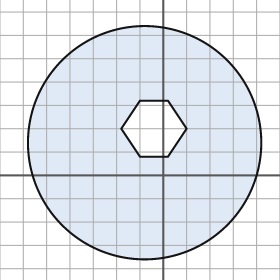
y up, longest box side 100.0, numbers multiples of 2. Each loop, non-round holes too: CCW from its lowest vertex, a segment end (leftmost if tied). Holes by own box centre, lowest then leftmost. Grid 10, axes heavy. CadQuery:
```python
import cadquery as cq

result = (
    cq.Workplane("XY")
    .moveTo(-8.0, 14.0)
    .circle(50.0)
    .moveTo(-10.0, 8.0)
    .lineTo(2.0, 8.0)
    .lineTo(10.0, 20.0)
    .lineTo(2.0, 32.0)
    .lineTo(-10.0, 32.0)
    .lineTo(-18.0, 20.0)
    .close()
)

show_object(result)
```